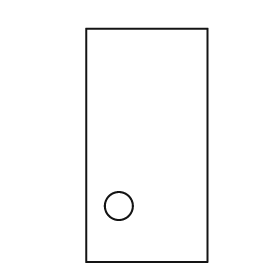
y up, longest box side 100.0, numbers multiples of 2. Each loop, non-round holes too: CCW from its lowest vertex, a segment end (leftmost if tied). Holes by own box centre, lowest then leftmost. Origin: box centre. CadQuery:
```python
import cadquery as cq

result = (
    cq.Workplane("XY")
    .moveTo(-26.0, -50.0)
    .lineTo(26.0, -50.0)
    .lineTo(26.0, 50.0)
    .lineTo(-26.0, 50.0)
    .close()
    .moveTo(-12.0, -26.0)
    .circle(6.0)
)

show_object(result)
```